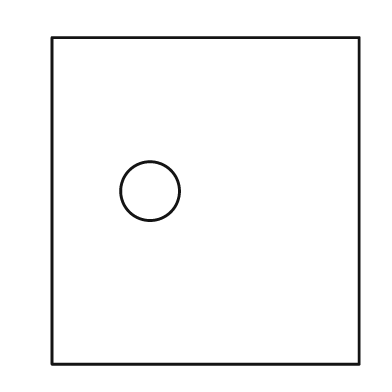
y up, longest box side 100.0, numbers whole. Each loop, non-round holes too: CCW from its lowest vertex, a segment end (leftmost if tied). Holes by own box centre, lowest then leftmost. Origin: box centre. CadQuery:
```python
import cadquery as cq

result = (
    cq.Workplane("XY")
    .moveTo(-47.0, -50.0)
    .lineTo(47.0, -50.0)
    .lineTo(47.0, 50.0)
    .lineTo(-47.0, 50.0)
    .close()
    .moveTo(-17.0, 3.0)
    .circle(9.0)
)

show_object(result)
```